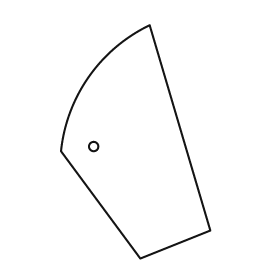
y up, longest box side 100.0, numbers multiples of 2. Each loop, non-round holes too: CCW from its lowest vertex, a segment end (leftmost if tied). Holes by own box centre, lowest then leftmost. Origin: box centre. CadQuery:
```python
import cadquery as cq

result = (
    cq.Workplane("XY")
    .moveTo(2.0, -50.0)
    .lineTo(32.0, -38.0)
    .lineTo(6.0, 50.0)
    .threePointArc((-20.0, 28.0), (-32.0, -4.0))
    .close()
    .moveTo(-18.0, -2.0)
    .circle(2.0)
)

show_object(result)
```